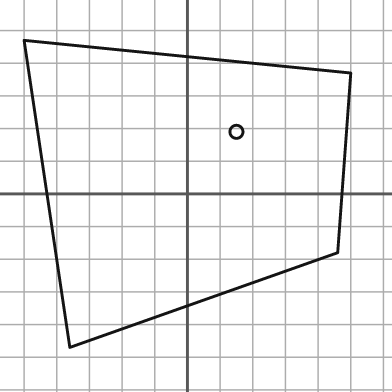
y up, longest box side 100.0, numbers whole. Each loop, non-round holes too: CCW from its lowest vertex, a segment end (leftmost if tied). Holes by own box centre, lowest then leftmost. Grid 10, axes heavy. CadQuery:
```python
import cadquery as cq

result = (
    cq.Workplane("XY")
    .moveTo(-36.0, -47.0)
    .lineTo(46.0, -18.0)
    .lineTo(50.0, 37.0)
    .lineTo(-50.0, 47.0)
    .close()
    .moveTo(15.0, 19.0)
    .circle(2.0)
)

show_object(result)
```